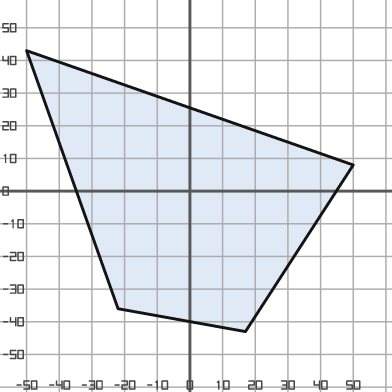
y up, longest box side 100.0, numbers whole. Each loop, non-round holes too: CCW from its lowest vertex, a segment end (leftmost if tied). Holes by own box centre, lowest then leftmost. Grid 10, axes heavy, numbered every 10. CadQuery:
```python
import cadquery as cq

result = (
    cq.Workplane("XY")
    .moveTo(17.0, -43.0)
    .lineTo(50.0, 8.0)
    .lineTo(-50.0, 43.0)
    .lineTo(-22.0, -36.0)
    .close()
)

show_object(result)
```